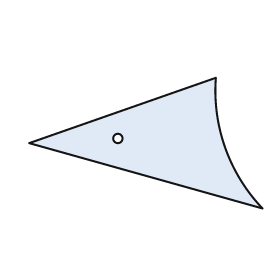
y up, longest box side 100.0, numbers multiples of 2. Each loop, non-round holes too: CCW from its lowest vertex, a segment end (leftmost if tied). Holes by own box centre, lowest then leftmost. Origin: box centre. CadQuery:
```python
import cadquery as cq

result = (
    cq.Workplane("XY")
    .moveTo(50.0, -28.0)
    .threePointArc((34.0, -2.0), (30.0, 28.0))
    .lineTo(-50.0, 0.0)
    .close()
    .moveTo(-12.0, 2.0)
    .circle(2.0)
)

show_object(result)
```